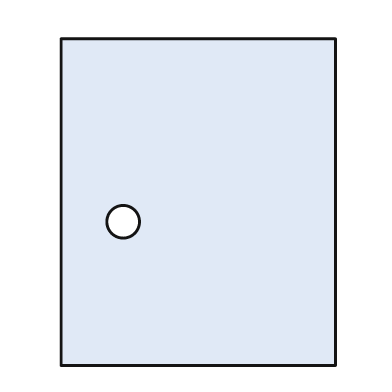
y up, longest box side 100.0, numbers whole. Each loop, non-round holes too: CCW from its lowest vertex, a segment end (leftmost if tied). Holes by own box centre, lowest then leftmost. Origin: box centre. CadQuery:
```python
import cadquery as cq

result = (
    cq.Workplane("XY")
    .moveTo(-42.0, -50.0)
    .lineTo(42.0, -50.0)
    .lineTo(42.0, 50.0)
    .lineTo(-42.0, 50.0)
    .close()
    .moveTo(-23.0, -6.0)
    .circle(5.0)
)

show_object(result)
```